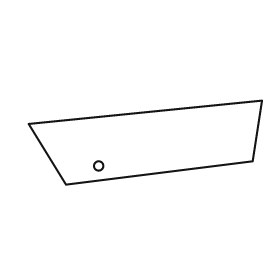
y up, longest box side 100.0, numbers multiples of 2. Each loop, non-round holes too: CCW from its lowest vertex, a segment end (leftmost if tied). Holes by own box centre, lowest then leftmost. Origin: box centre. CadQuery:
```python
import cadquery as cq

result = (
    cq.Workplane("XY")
    .moveTo(-34.0, -18.0)
    .lineTo(46.0, -8.0)
    .lineTo(50.0, 18.0)
    .lineTo(-50.0, 8.0)
    .close()
    .moveTo(-20.0, -10.0)
    .circle(2.0)
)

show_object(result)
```